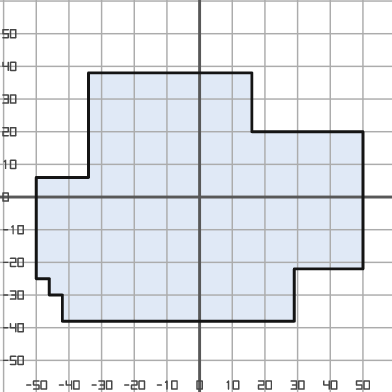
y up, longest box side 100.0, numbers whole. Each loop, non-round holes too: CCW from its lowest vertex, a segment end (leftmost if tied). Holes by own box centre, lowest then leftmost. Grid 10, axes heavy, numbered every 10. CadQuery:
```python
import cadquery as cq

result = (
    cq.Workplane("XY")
    .moveTo(-42.0, -38.0)
    .lineTo(29.0, -38.0)
    .lineTo(29.0, -22.0)
    .lineTo(50.0, -22.0)
    .lineTo(50.0, 20.0)
    .lineTo(16.0, 20.0)
    .lineTo(16.0, 38.0)
    .lineTo(-34.0, 38.0)
    .lineTo(-34.0, 6.0)
    .lineTo(-50.0, 6.0)
    .lineTo(-50.0, -25.0)
    .lineTo(-46.0, -25.0)
    .lineTo(-46.0, -30.0)
    .lineTo(-42.0, -30.0)
    .close()
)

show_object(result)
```